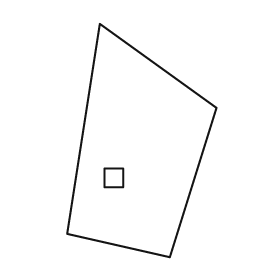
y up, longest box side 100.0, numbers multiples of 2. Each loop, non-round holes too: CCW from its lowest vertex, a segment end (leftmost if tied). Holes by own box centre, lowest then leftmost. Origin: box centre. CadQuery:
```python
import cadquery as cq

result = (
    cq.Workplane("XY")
    .moveTo(12.0, -50.0)
    .lineTo(32.0, 14.0)
    .lineTo(-18.0, 50.0)
    .lineTo(-32.0, -40.0)
    .close()
    .moveTo(-16.0, -20.0)
    .lineTo(-8.0, -20.0)
    .lineTo(-8.0, -12.0)
    .lineTo(-16.0, -12.0)
    .close()
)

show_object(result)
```